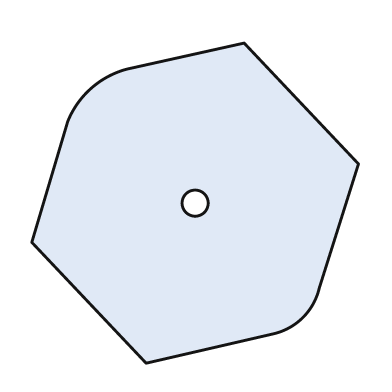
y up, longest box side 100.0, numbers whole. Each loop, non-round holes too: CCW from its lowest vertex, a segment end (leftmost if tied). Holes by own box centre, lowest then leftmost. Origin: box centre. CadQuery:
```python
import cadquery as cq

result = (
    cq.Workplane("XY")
    .moveTo(-15.0, -49.0)
    .lineTo(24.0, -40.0)
    .threePointArc((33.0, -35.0), (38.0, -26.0))
    .lineTo(50.0, 12.0)
    .lineTo(15.0, 49.0)
    .lineTo(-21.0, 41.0)
    .threePointArc((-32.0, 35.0), (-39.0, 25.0))
    .lineTo(-50.0, -12.0)
    .close()
    .moveTo(0.0, 0.0)
    .circle(4.0)
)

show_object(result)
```